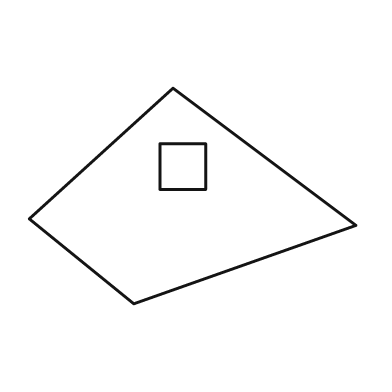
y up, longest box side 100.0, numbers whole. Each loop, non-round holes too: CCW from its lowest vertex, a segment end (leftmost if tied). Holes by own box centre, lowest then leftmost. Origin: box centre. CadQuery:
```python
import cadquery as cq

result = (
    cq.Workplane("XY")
    .moveTo(-18.0, -33.0)
    .lineTo(50.0, -9.0)
    .lineTo(-6.0, 33.0)
    .lineTo(-50.0, -7.0)
    .close()
    .moveTo(-10.0, 2.0)
    .lineTo(4.0, 2.0)
    .lineTo(4.0, 16.0)
    .lineTo(-10.0, 16.0)
    .close()
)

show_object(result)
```